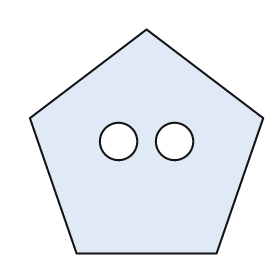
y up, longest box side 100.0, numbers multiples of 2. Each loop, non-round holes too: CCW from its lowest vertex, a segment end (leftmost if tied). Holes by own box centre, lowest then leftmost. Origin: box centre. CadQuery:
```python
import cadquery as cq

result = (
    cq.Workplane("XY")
    .moveTo(-30.0, -48.0)
    .lineTo(30.0, -48.0)
    .lineTo(50.0, 10.0)
    .lineTo(0.0, 48.0)
    .lineTo(-50.0, 10.0)
    .close()
    .moveTo(-12.0, 0.0)
    .circle(8.0)
    .moveTo(12.0, 0.0)
    .circle(8.0)
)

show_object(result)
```